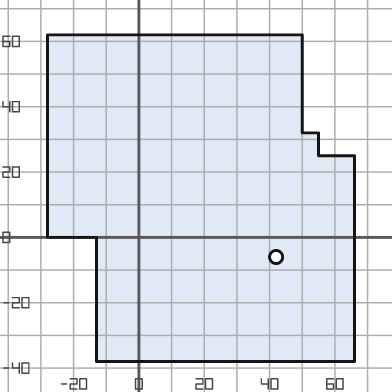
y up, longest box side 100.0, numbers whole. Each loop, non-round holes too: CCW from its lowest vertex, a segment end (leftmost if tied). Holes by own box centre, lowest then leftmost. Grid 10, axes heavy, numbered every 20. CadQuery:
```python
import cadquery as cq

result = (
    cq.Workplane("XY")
    .moveTo(-13.0, -38.0)
    .lineTo(66.0, -38.0)
    .lineTo(66.0, 25.0)
    .lineTo(55.0, 25.0)
    .lineTo(55.0, 32.0)
    .lineTo(50.0, 32.0)
    .lineTo(50.0, 62.0)
    .lineTo(-28.0, 62.0)
    .lineTo(-28.0, 0.0)
    .lineTo(-13.0, 0.0)
    .close()
    .moveTo(42.0, -6.0)
    .circle(2.0)
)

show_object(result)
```